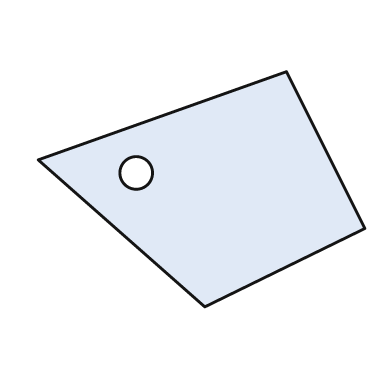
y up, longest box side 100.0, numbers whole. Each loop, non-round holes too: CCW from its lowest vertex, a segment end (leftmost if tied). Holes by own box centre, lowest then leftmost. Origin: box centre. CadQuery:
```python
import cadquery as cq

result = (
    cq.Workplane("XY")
    .moveTo(1.0, -36.0)
    .lineTo(50.0, -12.0)
    .lineTo(26.0, 36.0)
    .lineTo(-50.0, 9.0)
    .close()
    .moveTo(-20.0, 5.0)
    .circle(5.0)
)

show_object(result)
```